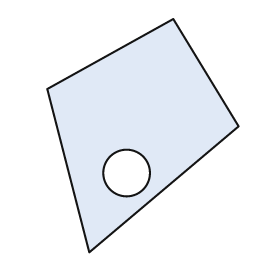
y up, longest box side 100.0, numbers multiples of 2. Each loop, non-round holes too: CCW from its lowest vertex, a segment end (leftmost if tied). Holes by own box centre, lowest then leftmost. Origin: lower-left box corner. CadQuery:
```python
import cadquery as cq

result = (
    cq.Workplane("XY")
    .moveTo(18.0, 0.0)
    .lineTo(82.0, 54.0)
    .lineTo(54.0, 100.0)
    .lineTo(0.0, 70.0)
    .close()
    .moveTo(34.0, 34.0)
    .circle(10.0)
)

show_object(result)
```